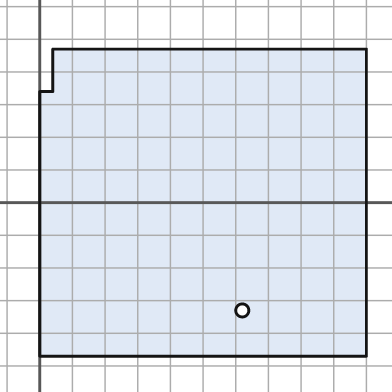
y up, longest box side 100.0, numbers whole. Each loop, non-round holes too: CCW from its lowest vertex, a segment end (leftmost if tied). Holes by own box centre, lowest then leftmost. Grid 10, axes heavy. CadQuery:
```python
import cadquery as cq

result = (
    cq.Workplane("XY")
    .moveTo(0.0, -47.0)
    .lineTo(100.0, -47.0)
    .lineTo(100.0, 47.0)
    .lineTo(4.0, 47.0)
    .lineTo(4.0, 34.0)
    .lineTo(0.0, 34.0)
    .close()
    .moveTo(62.0, -33.0)
    .circle(2.0)
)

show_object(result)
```